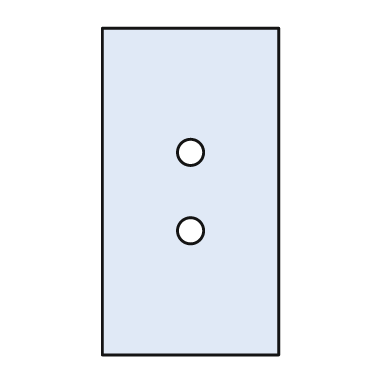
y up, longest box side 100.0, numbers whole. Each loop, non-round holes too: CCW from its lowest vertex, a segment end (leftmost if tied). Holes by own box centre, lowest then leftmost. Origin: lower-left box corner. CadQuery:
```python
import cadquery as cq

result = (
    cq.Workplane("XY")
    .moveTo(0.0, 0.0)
    .lineTo(54.0, 0.0)
    .lineTo(54.0, 100.0)
    .lineTo(0.0, 100.0)
    .close()
    .moveTo(27.0, 38.0)
    .circle(4.0)
    .moveTo(27.0, 62.0)
    .circle(4.0)
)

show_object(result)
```